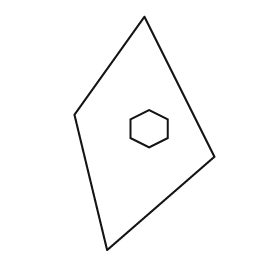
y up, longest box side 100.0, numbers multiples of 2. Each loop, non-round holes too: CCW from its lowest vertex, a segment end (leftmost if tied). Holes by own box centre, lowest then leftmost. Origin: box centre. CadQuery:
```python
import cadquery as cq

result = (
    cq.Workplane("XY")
    .moveTo(-16.0, -50.0)
    .lineTo(30.0, -10.0)
    .lineTo(0.0, 50.0)
    .lineTo(-30.0, 8.0)
    .close()
    .moveTo(2.0, -6.0)
    .lineTo(10.0, -2.0)
    .lineTo(10.0, 6.0)
    .lineTo(2.0, 10.0)
    .lineTo(-6.0, 6.0)
    .lineTo(-6.0, -2.0)
    .close()
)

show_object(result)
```